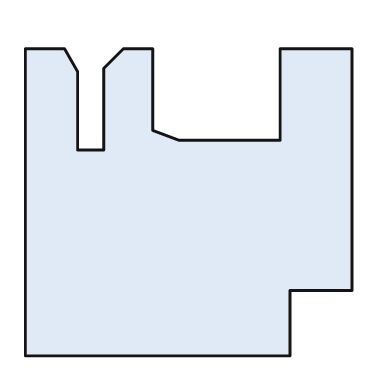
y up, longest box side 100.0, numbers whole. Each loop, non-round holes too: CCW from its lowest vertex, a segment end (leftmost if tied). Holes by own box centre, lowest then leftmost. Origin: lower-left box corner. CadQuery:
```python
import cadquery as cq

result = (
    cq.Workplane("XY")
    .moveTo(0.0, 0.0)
    .lineTo(81.0, 0.0)
    .lineTo(81.0, 20.0)
    .lineTo(100.0, 20.0)
    .lineTo(100.0, 94.0)
    .lineTo(78.0, 94.0)
    .lineTo(78.0, 66.0)
    .lineTo(47.0, 66.0)
    .lineTo(39.0, 69.0)
    .lineTo(39.0, 94.0)
    .lineTo(30.0, 94.0)
    .lineTo(24.0, 88.0)
    .lineTo(24.0, 63.0)
    .lineTo(16.0, 63.0)
    .lineTo(16.0, 87.0)
    .lineTo(12.0, 94.0)
    .lineTo(0.0, 94.0)
    .close()
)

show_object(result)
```